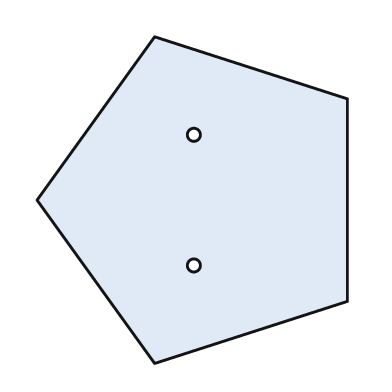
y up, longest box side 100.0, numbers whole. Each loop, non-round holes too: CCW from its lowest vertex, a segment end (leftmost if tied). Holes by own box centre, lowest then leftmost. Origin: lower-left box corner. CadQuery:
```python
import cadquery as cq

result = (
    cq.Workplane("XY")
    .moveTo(36.0, 0.0)
    .lineTo(95.0, 19.0)
    .lineTo(95.0, 81.0)
    .lineTo(36.0, 100.0)
    .lineTo(0.0, 50.0)
    .close()
    .moveTo(48.0, 30.0)
    .circle(2.0)
    .moveTo(48.0, 70.0)
    .circle(2.0)
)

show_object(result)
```